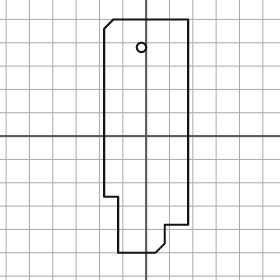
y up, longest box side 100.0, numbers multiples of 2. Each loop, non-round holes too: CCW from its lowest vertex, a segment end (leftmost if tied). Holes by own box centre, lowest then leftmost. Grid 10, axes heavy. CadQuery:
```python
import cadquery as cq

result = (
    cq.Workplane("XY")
    .moveTo(-12.0, -50.0)
    .lineTo(4.0, -50.0)
    .lineTo(8.0, -46.0)
    .lineTo(8.0, -38.0)
    .lineTo(18.0, -38.0)
    .lineTo(18.0, 50.0)
    .lineTo(-14.0, 50.0)
    .lineTo(-18.0, 46.0)
    .lineTo(-18.0, -26.0)
    .lineTo(-12.0, -26.0)
    .close()
    .moveTo(-2.0, 38.0)
    .circle(2.0)
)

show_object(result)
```